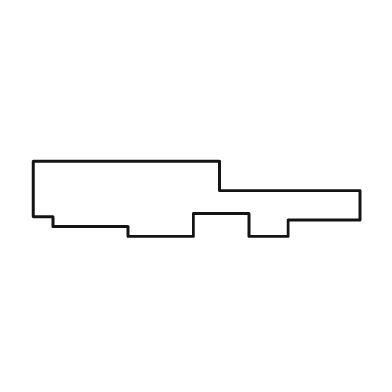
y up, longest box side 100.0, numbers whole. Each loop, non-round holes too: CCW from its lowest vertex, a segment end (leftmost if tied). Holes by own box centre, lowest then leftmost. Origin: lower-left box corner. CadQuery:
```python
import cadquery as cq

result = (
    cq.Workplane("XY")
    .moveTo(29.0, 0.0)
    .lineTo(49.0, 0.0)
    .lineTo(49.0, 7.0)
    .lineTo(66.0, 7.0)
    .lineTo(66.0, 0.0)
    .lineTo(78.0, 0.0)
    .lineTo(78.0, 5.0)
    .lineTo(100.0, 5.0)
    .lineTo(100.0, 14.0)
    .lineTo(57.0, 14.0)
    .lineTo(57.0, 23.0)
    .lineTo(0.0, 23.0)
    .lineTo(0.0, 6.0)
    .lineTo(6.0, 6.0)
    .lineTo(6.0, 3.0)
    .lineTo(29.0, 3.0)
    .close()
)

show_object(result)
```